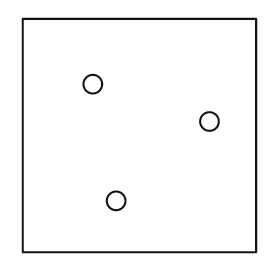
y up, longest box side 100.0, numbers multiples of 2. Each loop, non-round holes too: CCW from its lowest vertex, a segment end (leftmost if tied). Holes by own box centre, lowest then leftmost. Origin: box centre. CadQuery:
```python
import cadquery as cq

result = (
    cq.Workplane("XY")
    .moveTo(-50.0, -50.0)
    .lineTo(50.0, -50.0)
    .lineTo(50.0, 50.0)
    .lineTo(-50.0, 50.0)
    .close()
    .moveTo(-10.0, -28.0)
    .circle(4.0)
    .moveTo(30.0, 6.0)
    .circle(4.0)
    .moveTo(-20.0, 22.0)
    .circle(4.0)
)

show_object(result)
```